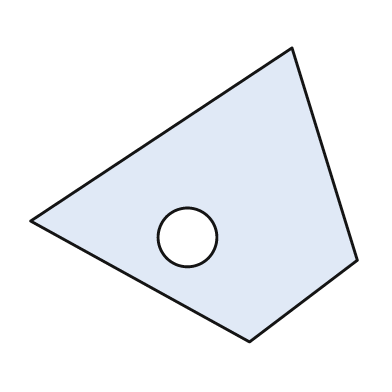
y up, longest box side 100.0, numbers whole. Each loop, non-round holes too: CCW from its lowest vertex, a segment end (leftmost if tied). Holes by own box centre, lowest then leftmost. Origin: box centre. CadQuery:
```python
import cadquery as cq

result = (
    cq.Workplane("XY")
    .moveTo(17.0, -45.0)
    .lineTo(50.0, -20.0)
    .lineTo(30.0, 45.0)
    .lineTo(-50.0, -8.0)
    .close()
    .moveTo(-2.0, -13.0)
    .circle(9.0)
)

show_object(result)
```